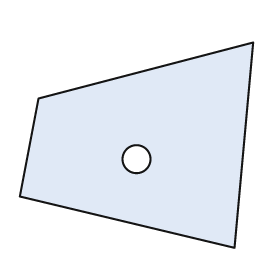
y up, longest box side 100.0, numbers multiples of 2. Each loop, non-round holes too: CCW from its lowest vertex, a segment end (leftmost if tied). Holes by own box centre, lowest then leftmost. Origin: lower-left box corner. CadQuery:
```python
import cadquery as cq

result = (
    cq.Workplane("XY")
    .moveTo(92.0, 0.0)
    .lineTo(100.0, 88.0)
    .lineTo(8.0, 64.0)
    .lineTo(0.0, 22.0)
    .close()
    .moveTo(50.0, 38.0)
    .circle(6.0)
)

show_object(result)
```